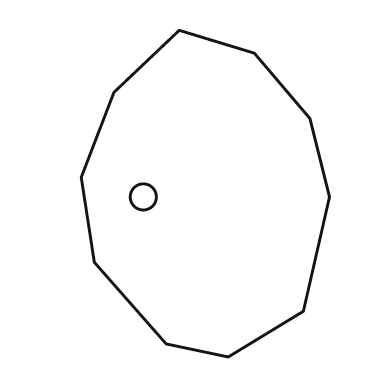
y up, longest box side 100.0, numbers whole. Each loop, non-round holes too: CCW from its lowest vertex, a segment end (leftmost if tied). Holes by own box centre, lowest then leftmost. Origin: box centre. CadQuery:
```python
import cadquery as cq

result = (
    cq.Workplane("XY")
    .moveTo(7.0, -50.0)
    .lineTo(30.0, -36.0)
    .lineTo(38.0, -1.0)
    .lineTo(32.0, 23.0)
    .lineTo(15.0, 43.0)
    .lineTo(-8.0, 50.0)
    .lineTo(-28.0, 31.0)
    .lineTo(-38.0, 5.0)
    .lineTo(-34.0, -21.0)
    .lineTo(-12.0, -46.0)
    .close()
    .moveTo(-19.0, -1.0)
    .circle(4.0)
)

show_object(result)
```